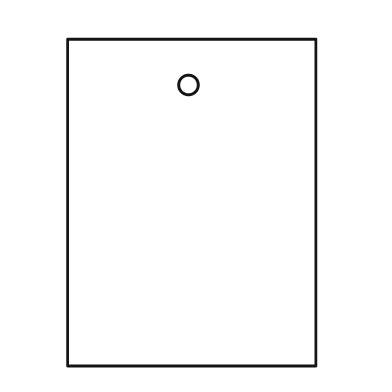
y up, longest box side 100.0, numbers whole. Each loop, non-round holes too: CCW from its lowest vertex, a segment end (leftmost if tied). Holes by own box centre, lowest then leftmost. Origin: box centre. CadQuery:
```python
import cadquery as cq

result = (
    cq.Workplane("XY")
    .moveTo(-38.0, -50.0)
    .lineTo(38.0, -50.0)
    .lineTo(38.0, 50.0)
    .lineTo(-38.0, 50.0)
    .close()
    .moveTo(-1.0, 36.0)
    .circle(3.0)
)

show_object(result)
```